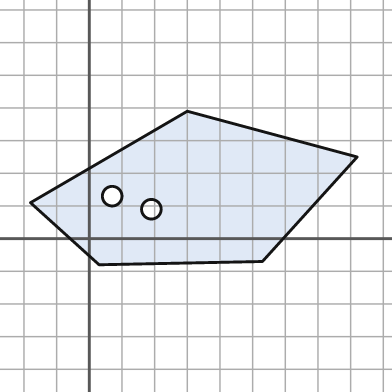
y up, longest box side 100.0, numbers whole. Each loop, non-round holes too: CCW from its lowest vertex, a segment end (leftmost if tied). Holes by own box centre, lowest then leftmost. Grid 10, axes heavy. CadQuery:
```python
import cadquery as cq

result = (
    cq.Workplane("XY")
    .moveTo(3.0, -8.0)
    .lineTo(53.0, -7.0)
    .lineTo(82.0, 25.0)
    .lineTo(30.0, 39.0)
    .lineTo(-18.0, 11.0)
    .close()
    .moveTo(19.0, 9.0)
    .circle(3.0)
    .moveTo(7.0, 13.0)
    .circle(3.0)
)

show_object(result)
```